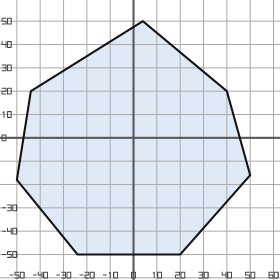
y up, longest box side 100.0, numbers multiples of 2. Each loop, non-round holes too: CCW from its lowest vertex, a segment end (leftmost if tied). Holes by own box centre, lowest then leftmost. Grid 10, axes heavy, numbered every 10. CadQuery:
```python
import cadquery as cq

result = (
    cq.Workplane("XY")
    .moveTo(-24.0, -50.0)
    .lineTo(20.0, -50.0)
    .lineTo(50.0, -16.0)
    .lineTo(40.0, 20.0)
    .lineTo(4.0, 50.0)
    .lineTo(-44.0, 20.0)
    .lineTo(-50.0, -18.0)
    .close()
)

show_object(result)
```